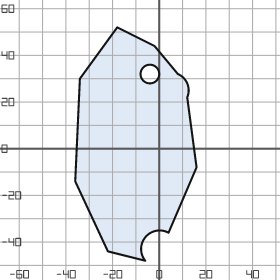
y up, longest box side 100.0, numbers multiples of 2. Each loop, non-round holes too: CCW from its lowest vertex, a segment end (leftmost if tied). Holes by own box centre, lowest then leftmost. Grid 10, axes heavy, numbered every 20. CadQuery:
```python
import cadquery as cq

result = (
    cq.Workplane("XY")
    .moveTo(-6.0, -48.0)
    .threePointArc((-6.0, -38.0), (4.0, -36.0))
    .lineTo(16.0, -8.0)
    .lineTo(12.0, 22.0)
    .threePointArc((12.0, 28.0), (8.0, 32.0))
    .lineTo(-2.0, 44.0)
    .lineTo(-18.0, 52.0)
    .lineTo(-34.0, 30.0)
    .lineTo(-36.0, -14.0)
    .lineTo(-22.0, -44.0)
    .close()
    .moveTo(-4.0, 32.0)
    .circle(4.0)
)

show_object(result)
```